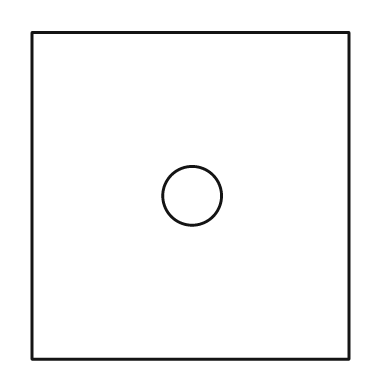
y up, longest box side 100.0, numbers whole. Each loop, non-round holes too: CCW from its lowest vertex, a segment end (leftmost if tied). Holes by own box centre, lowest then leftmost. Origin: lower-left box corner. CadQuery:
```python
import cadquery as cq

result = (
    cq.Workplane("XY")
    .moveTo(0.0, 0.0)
    .lineTo(97.0, 0.0)
    .lineTo(97.0, 100.0)
    .lineTo(0.0, 100.0)
    .close()
    .moveTo(49.0, 50.0)
    .circle(9.0)
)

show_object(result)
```